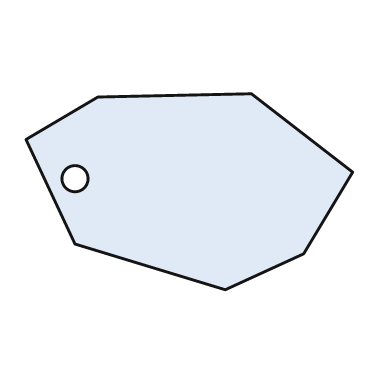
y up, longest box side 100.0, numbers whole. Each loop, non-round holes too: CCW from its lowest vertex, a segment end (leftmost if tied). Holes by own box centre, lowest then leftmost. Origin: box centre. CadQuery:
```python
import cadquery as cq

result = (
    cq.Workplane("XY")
    .moveTo(11.0, -30.0)
    .lineTo(35.0, -19.0)
    .lineTo(50.0, 6.0)
    .lineTo(19.0, 30.0)
    .lineTo(-28.0, 29.0)
    .lineTo(-50.0, 16.0)
    .lineTo(-35.0, -16.0)
    .close()
    .moveTo(-35.0, 4.0)
    .circle(4.0)
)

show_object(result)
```